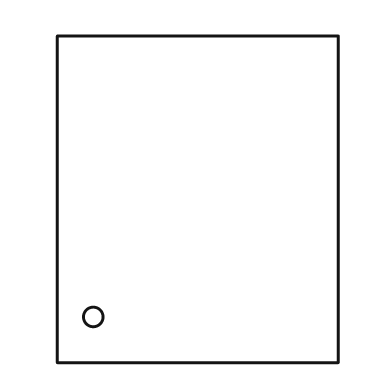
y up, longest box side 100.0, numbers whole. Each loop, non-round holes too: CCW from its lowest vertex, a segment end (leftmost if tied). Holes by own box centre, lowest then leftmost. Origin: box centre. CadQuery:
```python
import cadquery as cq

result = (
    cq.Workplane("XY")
    .moveTo(-43.0, -50.0)
    .lineTo(43.0, -50.0)
    .lineTo(43.0, 50.0)
    .lineTo(-43.0, 50.0)
    .close()
    .moveTo(-32.0, -36.0)
    .circle(3.0)
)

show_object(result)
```